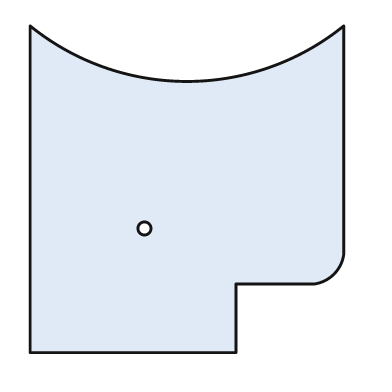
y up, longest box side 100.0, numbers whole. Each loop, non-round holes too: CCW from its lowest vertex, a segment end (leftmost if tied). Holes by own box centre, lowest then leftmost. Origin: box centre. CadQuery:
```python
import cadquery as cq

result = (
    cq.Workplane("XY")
    .moveTo(-48.0, -50.0)
    .lineTo(15.0, -50.0)
    .lineTo(15.0, -29.0)
    .lineTo(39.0, -29.0)
    .threePointArc((45.0, -26.0), (48.0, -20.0))
    .lineTo(48.0, 50.0)
    .threePointArc((0.0, 33.0), (-48.0, 50.0))
    .close()
    .moveTo(-13.0, -12.0)
    .circle(2.0)
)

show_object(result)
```